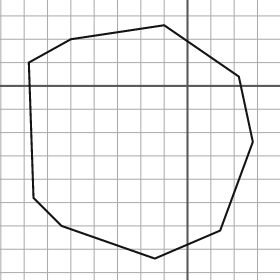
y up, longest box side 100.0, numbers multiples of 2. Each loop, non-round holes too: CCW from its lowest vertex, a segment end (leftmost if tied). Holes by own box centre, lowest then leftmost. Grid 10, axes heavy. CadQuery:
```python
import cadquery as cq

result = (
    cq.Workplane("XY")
    .moveTo(-14.0, -74.0)
    .lineTo(14.0, -62.0)
    .lineTo(28.0, -24.0)
    .lineTo(22.0, 4.0)
    .lineTo(-10.0, 26.0)
    .lineTo(-50.0, 20.0)
    .lineTo(-68.0, 10.0)
    .lineTo(-66.0, -48.0)
    .lineTo(-54.0, -60.0)
    .close()
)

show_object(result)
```